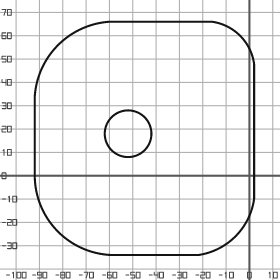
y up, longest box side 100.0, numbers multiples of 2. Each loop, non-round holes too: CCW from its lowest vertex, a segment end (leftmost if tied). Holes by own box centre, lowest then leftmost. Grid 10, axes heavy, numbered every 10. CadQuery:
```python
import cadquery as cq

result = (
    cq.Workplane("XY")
    .moveTo(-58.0, -34.0)
    .lineTo(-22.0, -34.0)
    .threePointArc((-6.0, -26.0), (2.0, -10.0))
    .lineTo(2.0, 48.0)
    .threePointArc((-4.0, 60.0), (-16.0, 66.0))
    .lineTo(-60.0, 66.0)
    .threePointArc((-82.0, 56.0), (-92.0, 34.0))
    .lineTo(-92.0, 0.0)
    .threePointArc((-82.0, -24.0), (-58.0, -34.0))
    .close()
    .moveTo(-52.0, 18.0)
    .circle(10.0)
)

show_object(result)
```